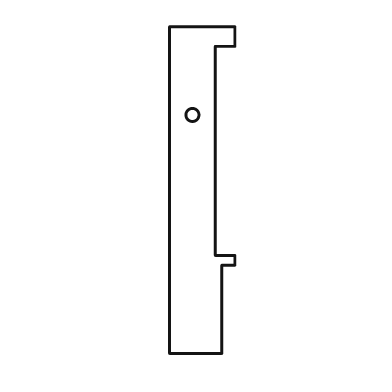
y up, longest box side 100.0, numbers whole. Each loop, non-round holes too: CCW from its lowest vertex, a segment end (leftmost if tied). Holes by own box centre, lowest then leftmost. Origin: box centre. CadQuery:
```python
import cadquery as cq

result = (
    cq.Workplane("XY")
    .moveTo(-10.0, -50.0)
    .lineTo(6.0, -50.0)
    .lineTo(6.0, -23.0)
    .lineTo(10.0, -23.0)
    .lineTo(10.0, -20.0)
    .lineTo(4.0, -20.0)
    .lineTo(4.0, 44.0)
    .lineTo(10.0, 44.0)
    .lineTo(10.0, 50.0)
    .lineTo(-10.0, 50.0)
    .close()
    .moveTo(-3.0, 23.0)
    .circle(2.0)
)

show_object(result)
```